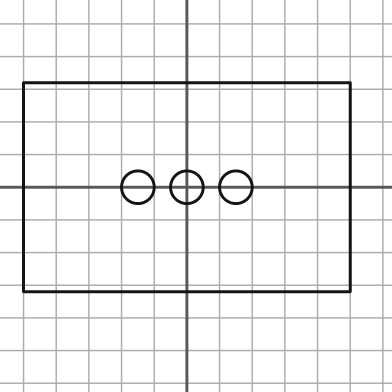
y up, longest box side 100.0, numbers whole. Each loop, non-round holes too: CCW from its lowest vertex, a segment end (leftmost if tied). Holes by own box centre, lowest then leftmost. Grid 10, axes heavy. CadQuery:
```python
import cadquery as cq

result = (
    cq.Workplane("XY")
    .moveTo(-50.0, -32.0)
    .lineTo(50.0, -32.0)
    .lineTo(50.0, 32.0)
    .lineTo(-50.0, 32.0)
    .close()
    .moveTo(-15.0, 0.0)
    .circle(5.0)
    .moveTo(0.0, 0.0)
    .circle(5.0)
    .moveTo(15.0, 0.0)
    .circle(5.0)
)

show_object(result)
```